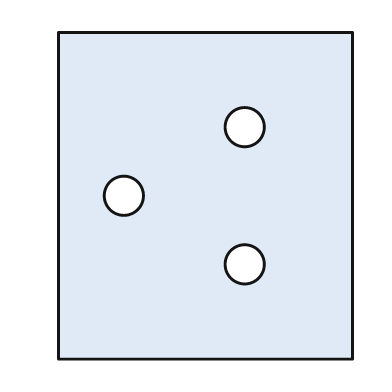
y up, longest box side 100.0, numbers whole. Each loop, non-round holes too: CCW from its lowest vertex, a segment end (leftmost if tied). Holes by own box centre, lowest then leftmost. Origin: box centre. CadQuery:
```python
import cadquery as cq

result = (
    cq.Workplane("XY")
    .moveTo(-45.0, -50.0)
    .lineTo(45.0, -50.0)
    .lineTo(45.0, 50.0)
    .lineTo(-45.0, 50.0)
    .close()
    .moveTo(12.0, -21.0)
    .circle(6.0)
    .moveTo(-25.0, 0.0)
    .circle(6.0)
    .moveTo(12.0, 21.0)
    .circle(6.0)
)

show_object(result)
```